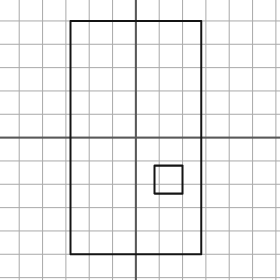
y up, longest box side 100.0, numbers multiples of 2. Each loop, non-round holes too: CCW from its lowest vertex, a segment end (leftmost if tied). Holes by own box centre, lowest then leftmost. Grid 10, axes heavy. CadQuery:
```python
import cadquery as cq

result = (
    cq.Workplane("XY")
    .moveTo(-28.0, -50.0)
    .lineTo(28.0, -50.0)
    .lineTo(28.0, 50.0)
    .lineTo(-28.0, 50.0)
    .close()
    .moveTo(8.0, -24.0)
    .lineTo(20.0, -24.0)
    .lineTo(20.0, -12.0)
    .lineTo(8.0, -12.0)
    .close()
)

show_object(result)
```